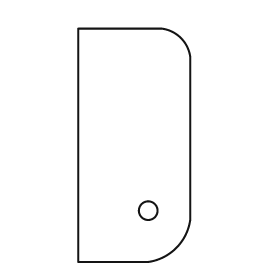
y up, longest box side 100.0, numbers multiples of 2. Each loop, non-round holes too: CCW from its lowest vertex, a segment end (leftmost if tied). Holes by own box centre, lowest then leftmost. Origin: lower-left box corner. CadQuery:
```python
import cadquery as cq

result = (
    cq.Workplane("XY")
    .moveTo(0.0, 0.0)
    .lineTo(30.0, 0.0)
    .threePointArc((42.0, 6.0), (48.0, 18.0))
    .lineTo(48.0, 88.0)
    .threePointArc((44.0, 96.0), (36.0, 100.0))
    .lineTo(0.0, 100.0)
    .close()
    .moveTo(30.0, 22.0)
    .circle(4.0)
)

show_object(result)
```